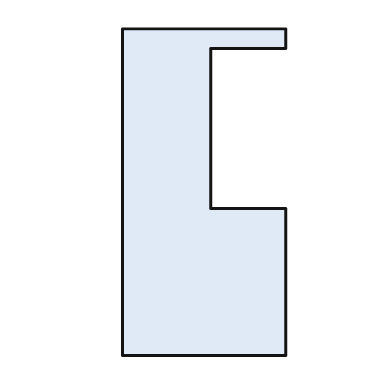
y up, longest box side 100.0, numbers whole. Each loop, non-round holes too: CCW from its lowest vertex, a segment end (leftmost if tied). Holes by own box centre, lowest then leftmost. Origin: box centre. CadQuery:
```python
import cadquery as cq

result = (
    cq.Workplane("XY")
    .moveTo(-25.0, -50.0)
    .lineTo(25.0, -50.0)
    .lineTo(25.0, -5.0)
    .lineTo(2.0, -5.0)
    .lineTo(2.0, 44.0)
    .lineTo(25.0, 44.0)
    .lineTo(25.0, 50.0)
    .lineTo(-25.0, 50.0)
    .close()
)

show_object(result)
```